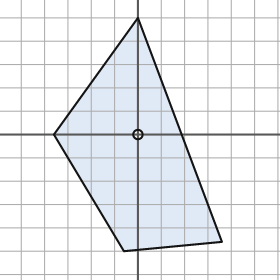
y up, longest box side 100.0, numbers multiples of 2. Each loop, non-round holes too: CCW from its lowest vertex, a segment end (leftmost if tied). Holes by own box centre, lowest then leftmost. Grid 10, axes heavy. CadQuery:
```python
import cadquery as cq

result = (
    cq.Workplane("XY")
    .moveTo(-6.0, -50.0)
    .lineTo(36.0, -46.0)
    .lineTo(0.0, 50.0)
    .lineTo(-36.0, 0.0)
    .close()
    .moveTo(0.0, 0.0)
    .circle(2.0)
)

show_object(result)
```